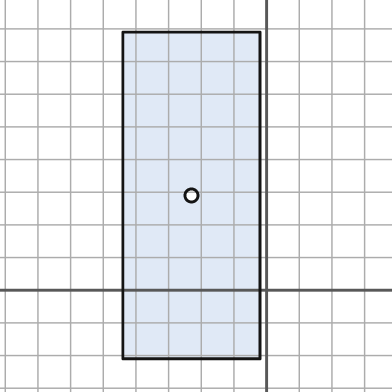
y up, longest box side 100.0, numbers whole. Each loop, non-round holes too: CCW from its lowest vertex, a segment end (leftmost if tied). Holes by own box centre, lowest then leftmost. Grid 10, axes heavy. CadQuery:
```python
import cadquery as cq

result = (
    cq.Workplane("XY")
    .moveTo(-44.0, -21.0)
    .lineTo(-2.0, -21.0)
    .lineTo(-2.0, 79.0)
    .lineTo(-44.0, 79.0)
    .close()
    .moveTo(-23.0, 29.0)
    .circle(2.0)
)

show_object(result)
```